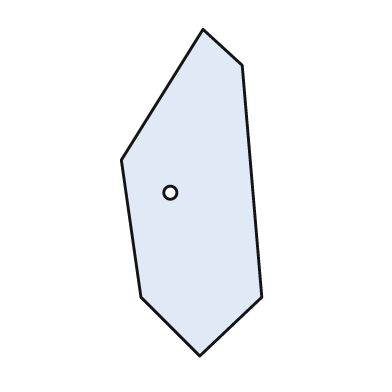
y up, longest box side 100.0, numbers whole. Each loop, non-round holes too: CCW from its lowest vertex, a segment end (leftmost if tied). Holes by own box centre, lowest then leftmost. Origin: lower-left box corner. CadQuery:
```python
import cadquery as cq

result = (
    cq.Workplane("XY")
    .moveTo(24.0, 0.0)
    .lineTo(43.0, 18.0)
    .lineTo(37.0, 89.0)
    .lineTo(25.0, 100.0)
    .lineTo(0.0, 60.0)
    .lineTo(6.0, 18.0)
    .close()
    .moveTo(15.0, 50.0)
    .circle(2.0)
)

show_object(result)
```